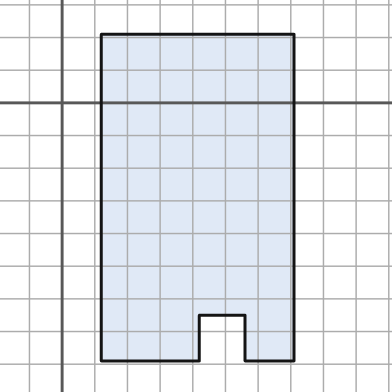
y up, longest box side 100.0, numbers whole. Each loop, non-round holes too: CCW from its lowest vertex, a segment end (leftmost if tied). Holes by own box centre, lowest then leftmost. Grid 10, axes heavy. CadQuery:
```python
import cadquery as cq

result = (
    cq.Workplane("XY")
    .moveTo(12.0, -79.0)
    .lineTo(42.0, -79.0)
    .lineTo(42.0, -65.0)
    .lineTo(56.0, -65.0)
    .lineTo(56.0, -79.0)
    .lineTo(71.0, -79.0)
    .lineTo(71.0, 21.0)
    .lineTo(12.0, 21.0)
    .close()
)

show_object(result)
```